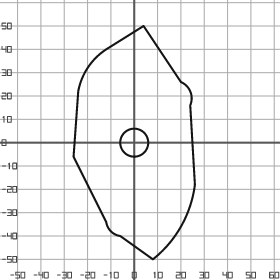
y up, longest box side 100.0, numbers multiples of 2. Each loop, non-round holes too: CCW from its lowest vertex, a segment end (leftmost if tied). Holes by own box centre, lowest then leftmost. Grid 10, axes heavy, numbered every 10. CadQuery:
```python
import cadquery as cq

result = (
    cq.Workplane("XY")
    .moveTo(8.0, -50.0)
    .threePointArc((20.0, -36.0), (26.0, -18.0))
    .lineTo(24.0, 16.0)
    .threePointArc((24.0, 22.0), (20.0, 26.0))
    .lineTo(4.0, 50.0)
    .lineTo(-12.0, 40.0)
    .threePointArc((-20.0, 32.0), (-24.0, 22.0))
    .lineTo(-26.0, -6.0)
    .lineTo(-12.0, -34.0)
    .threePointArc((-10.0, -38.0), (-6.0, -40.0))
    .close()
    .moveTo(0.0, 0.0)
    .circle(6.0)
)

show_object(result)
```